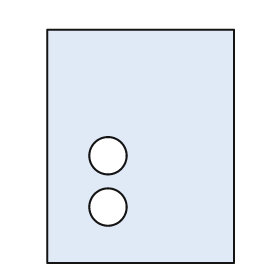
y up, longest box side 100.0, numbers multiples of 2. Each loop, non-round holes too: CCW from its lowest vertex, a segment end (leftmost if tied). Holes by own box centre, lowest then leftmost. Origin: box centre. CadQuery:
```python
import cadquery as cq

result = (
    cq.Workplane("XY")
    .moveTo(-40.0, -50.0)
    .lineTo(40.0, -50.0)
    .lineTo(40.0, 50.0)
    .lineTo(-40.0, 50.0)
    .close()
    .moveTo(-14.0, -26.0)
    .circle(8.0)
    .moveTo(-14.0, -4.0)
    .circle(8.0)
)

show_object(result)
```